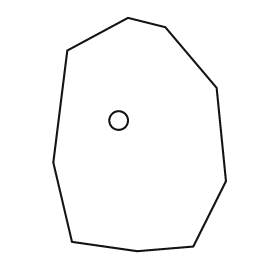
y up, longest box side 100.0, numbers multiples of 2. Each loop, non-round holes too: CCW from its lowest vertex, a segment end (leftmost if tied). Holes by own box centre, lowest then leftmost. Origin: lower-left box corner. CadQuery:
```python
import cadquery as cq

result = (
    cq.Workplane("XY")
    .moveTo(36.0, 0.0)
    .lineTo(60.0, 2.0)
    .lineTo(74.0, 30.0)
    .lineTo(70.0, 70.0)
    .lineTo(48.0, 96.0)
    .lineTo(32.0, 100.0)
    .lineTo(6.0, 86.0)
    .lineTo(0.0, 38.0)
    .lineTo(8.0, 4.0)
    .close()
    .moveTo(28.0, 56.0)
    .circle(4.0)
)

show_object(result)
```